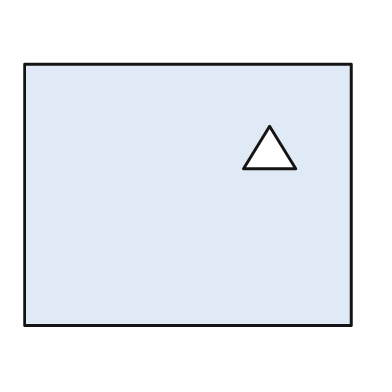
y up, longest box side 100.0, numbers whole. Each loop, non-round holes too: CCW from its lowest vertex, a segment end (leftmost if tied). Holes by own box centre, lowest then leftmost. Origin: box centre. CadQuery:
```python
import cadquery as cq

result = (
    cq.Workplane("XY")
    .moveTo(-50.0, -40.0)
    .lineTo(50.0, -40.0)
    .lineTo(50.0, 40.0)
    .lineTo(-50.0, 40.0)
    .close()
    .moveTo(17.0, 8.0)
    .lineTo(33.0, 8.0)
    .lineTo(25.0, 21.0)
    .close()
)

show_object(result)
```